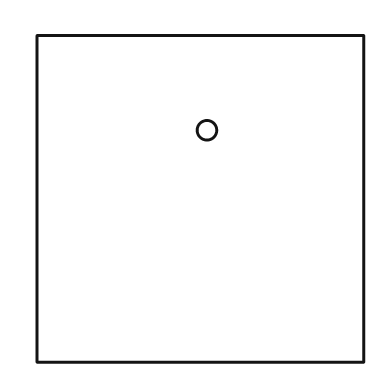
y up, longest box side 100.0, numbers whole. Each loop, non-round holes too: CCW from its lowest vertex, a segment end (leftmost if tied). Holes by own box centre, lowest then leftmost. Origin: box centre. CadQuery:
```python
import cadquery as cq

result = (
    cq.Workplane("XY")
    .moveTo(-50.0, -50.0)
    .lineTo(50.0, -50.0)
    .lineTo(50.0, 50.0)
    .lineTo(-50.0, 50.0)
    .close()
    .moveTo(2.0, 21.0)
    .circle(3.0)
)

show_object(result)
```